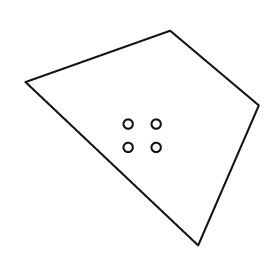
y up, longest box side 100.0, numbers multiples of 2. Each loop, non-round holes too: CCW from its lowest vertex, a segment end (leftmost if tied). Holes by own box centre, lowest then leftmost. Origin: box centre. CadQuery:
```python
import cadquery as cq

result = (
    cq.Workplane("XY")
    .moveTo(24.0, -46.0)
    .lineTo(50.0, 14.0)
    .lineTo(12.0, 46.0)
    .lineTo(-50.0, 24.0)
    .close()
    .moveTo(-6.0, -4.0)
    .circle(2.0)
    .moveTo(6.0, -4.0)
    .circle(2.0)
    .moveTo(-6.0, 6.0)
    .circle(2.0)
    .moveTo(6.0, 6.0)
    .circle(2.0)
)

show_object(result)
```